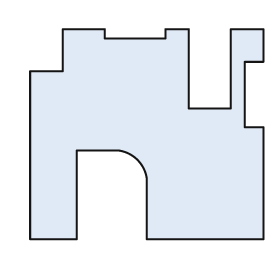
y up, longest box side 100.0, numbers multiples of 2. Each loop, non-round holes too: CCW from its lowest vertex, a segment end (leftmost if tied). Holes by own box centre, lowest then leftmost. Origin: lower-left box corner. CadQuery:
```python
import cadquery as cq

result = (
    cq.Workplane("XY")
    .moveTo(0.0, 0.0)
    .lineTo(20.0, 0.0)
    .lineTo(20.0, 38.0)
    .lineTo(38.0, 38.0)
    .threePointArc((46.0, 34.0), (50.0, 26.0))
    .lineTo(50.0, 0.0)
    .lineTo(100.0, 0.0)
    .lineTo(100.0, 48.0)
    .lineTo(92.0, 48.0)
    .lineTo(92.0, 76.0)
    .lineTo(100.0, 76.0)
    .lineTo(100.0, 90.0)
    .lineTo(86.0, 90.0)
    .lineTo(86.0, 56.0)
    .lineTo(68.0, 56.0)
    .lineTo(68.0, 90.0)
    .lineTo(58.0, 90.0)
    .lineTo(58.0, 86.0)
    .lineTo(32.0, 86.0)
    .lineTo(32.0, 90.0)
    .lineTo(14.0, 90.0)
    .lineTo(14.0, 72.0)
    .lineTo(0.0, 72.0)
    .close()
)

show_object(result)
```